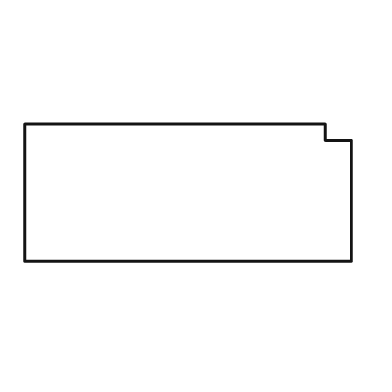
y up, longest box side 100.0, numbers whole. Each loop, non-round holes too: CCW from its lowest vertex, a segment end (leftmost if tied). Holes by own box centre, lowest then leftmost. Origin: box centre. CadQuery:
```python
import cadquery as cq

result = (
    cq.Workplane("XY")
    .moveTo(-50.0, -21.0)
    .lineTo(50.0, -21.0)
    .lineTo(50.0, 16.0)
    .lineTo(42.0, 16.0)
    .lineTo(42.0, 21.0)
    .lineTo(-50.0, 21.0)
    .close()
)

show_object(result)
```